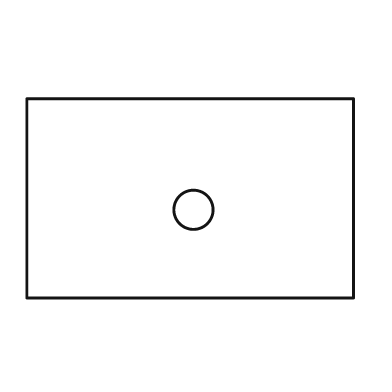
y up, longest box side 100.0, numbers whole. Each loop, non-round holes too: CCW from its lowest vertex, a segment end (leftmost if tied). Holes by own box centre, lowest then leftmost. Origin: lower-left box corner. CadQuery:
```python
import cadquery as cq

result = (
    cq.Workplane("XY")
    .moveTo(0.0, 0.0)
    .lineTo(100.0, 0.0)
    .lineTo(100.0, 61.0)
    .lineTo(0.0, 61.0)
    .close()
    .moveTo(51.0, 27.0)
    .circle(6.0)
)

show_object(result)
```